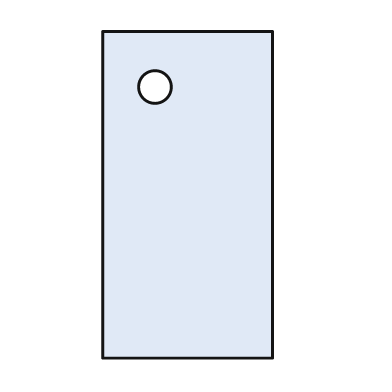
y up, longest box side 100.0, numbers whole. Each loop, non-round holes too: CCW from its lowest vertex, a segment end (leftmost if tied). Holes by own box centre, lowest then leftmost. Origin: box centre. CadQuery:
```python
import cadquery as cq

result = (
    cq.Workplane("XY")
    .moveTo(-26.0, -50.0)
    .lineTo(26.0, -50.0)
    .lineTo(26.0, 50.0)
    .lineTo(-26.0, 50.0)
    .close()
    .moveTo(-10.0, 33.0)
    .circle(5.0)
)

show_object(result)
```